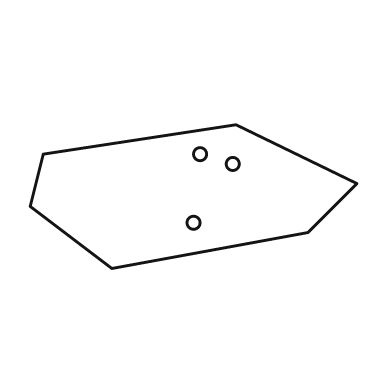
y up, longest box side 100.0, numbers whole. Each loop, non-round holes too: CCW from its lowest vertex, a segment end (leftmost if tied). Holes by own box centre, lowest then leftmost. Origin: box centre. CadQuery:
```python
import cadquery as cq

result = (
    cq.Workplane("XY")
    .moveTo(-25.0, -22.0)
    .lineTo(35.0, -11.0)
    .lineTo(50.0, 4.0)
    .lineTo(13.0, 22.0)
    .lineTo(-46.0, 13.0)
    .lineTo(-50.0, -3.0)
    .close()
    .moveTo(0.0, -8.0)
    .circle(2.0)
    .moveTo(12.0, 10.0)
    .circle(2.0)
    .moveTo(2.0, 13.0)
    .circle(2.0)
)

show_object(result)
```